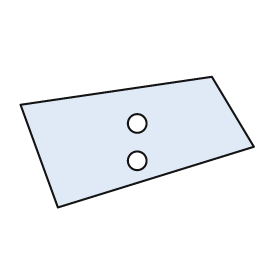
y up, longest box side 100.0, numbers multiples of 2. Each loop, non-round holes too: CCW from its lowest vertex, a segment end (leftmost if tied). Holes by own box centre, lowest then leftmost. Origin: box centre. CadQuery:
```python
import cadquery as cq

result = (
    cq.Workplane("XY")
    .moveTo(-34.0, -28.0)
    .lineTo(50.0, -2.0)
    .lineTo(32.0, 28.0)
    .lineTo(-50.0, 16.0)
    .close()
    .moveTo(0.0, -8.0)
    .circle(4.0)
    .moveTo(0.0, 8.0)
    .circle(4.0)
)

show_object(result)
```